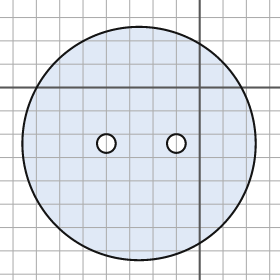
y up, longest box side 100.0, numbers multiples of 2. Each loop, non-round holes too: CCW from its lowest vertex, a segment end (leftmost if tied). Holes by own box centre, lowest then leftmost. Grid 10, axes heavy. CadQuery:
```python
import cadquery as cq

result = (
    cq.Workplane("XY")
    .moveTo(-26.0, -24.0)
    .circle(50.0)
    .moveTo(-40.0, -24.0)
    .circle(4.0)
    .moveTo(-10.0, -24.0)
    .circle(4.0)
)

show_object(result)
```